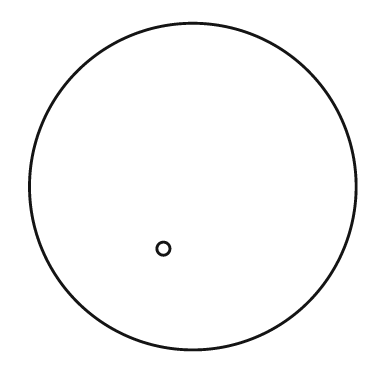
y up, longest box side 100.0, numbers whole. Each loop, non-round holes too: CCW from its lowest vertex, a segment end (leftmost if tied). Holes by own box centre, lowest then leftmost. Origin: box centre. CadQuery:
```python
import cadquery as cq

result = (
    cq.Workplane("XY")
    .moveTo(0.0, 0.0)
    .circle(50.0)
    .moveTo(-9.0, -19.0)
    .circle(2.0)
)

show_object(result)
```